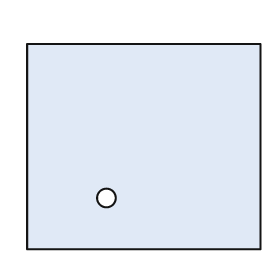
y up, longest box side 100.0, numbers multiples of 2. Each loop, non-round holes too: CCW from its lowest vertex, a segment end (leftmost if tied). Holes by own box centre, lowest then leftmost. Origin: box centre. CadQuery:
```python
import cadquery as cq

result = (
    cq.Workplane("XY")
    .moveTo(-50.0, -44.0)
    .lineTo(50.0, -44.0)
    .lineTo(50.0, 44.0)
    .lineTo(-50.0, 44.0)
    .close()
    .moveTo(-16.0, -22.0)
    .circle(4.0)
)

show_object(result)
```